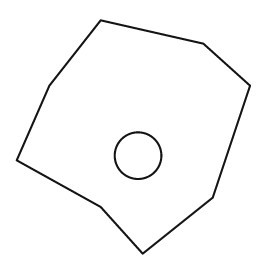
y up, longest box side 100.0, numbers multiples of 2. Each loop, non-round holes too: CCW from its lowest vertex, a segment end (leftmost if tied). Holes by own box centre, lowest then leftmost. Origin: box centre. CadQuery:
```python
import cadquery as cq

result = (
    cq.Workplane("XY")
    .moveTo(4.0, -50.0)
    .lineTo(34.0, -26.0)
    .lineTo(50.0, 22.0)
    .lineTo(30.0, 40.0)
    .lineTo(-14.0, 50.0)
    .lineTo(-36.0, 22.0)
    .lineTo(-50.0, -10.0)
    .lineTo(-14.0, -30.0)
    .close()
    .moveTo(2.0, -8.0)
    .circle(10.0)
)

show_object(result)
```